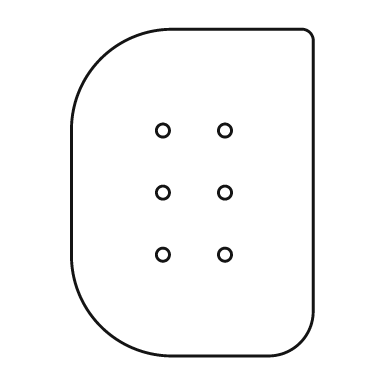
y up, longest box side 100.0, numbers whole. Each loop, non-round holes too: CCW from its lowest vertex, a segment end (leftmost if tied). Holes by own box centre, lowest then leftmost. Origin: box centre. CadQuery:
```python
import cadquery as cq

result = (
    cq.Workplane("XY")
    .moveTo(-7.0, -50.0)
    .lineTo(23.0, -50.0)
    .threePointArc((33.0, -46.0), (37.0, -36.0))
    .lineTo(37.0, 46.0)
    .threePointArc((36.0, 49.0), (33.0, 50.0))
    .lineTo(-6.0, 50.0)
    .threePointArc((-28.0, 41.0), (-37.0, 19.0))
    .lineTo(-37.0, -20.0)
    .threePointArc((-28.0, -41.0), (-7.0, -50.0))
    .close()
    .moveTo(-9.0, -19.0)
    .circle(2.0)
    .moveTo(10.0, -19.0)
    .circle(2.0)
    .moveTo(-9.0, 0.0)
    .circle(2.0)
    .moveTo(10.0, 0.0)
    .circle(2.0)
    .moveTo(-9.0, 19.0)
    .circle(2.0)
    .moveTo(10.0, 19.0)
    .circle(2.0)
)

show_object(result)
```